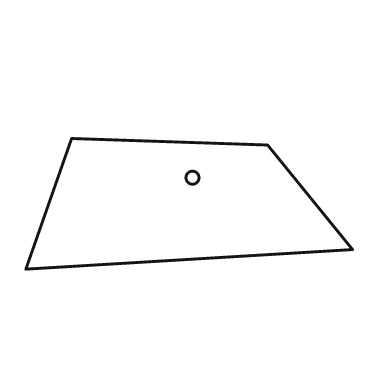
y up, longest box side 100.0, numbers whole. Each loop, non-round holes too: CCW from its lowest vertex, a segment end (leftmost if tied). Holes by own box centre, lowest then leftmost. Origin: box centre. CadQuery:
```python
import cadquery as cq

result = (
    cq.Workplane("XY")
    .moveTo(-50.0, -20.0)
    .lineTo(50.0, -14.0)
    .lineTo(24.0, 18.0)
    .lineTo(-36.0, 20.0)
    .close()
    .moveTo(1.0, 8.0)
    .circle(2.0)
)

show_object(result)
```